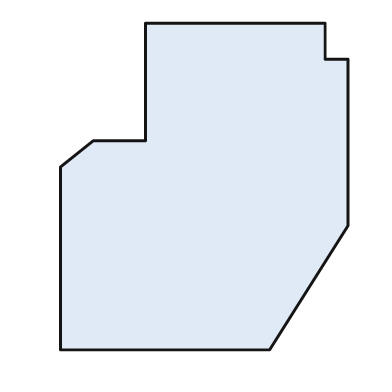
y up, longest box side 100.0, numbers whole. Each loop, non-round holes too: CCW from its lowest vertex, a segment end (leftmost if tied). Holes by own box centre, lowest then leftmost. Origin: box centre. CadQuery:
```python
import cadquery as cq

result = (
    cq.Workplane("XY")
    .moveTo(-44.0, -50.0)
    .lineTo(20.0, -50.0)
    .lineTo(44.0, -12.0)
    .lineTo(44.0, 39.0)
    .lineTo(37.0, 39.0)
    .lineTo(37.0, 50.0)
    .lineTo(-18.0, 50.0)
    .lineTo(-18.0, 14.0)
    .lineTo(-34.0, 14.0)
    .lineTo(-44.0, 6.0)
    .close()
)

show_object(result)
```